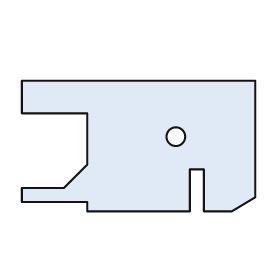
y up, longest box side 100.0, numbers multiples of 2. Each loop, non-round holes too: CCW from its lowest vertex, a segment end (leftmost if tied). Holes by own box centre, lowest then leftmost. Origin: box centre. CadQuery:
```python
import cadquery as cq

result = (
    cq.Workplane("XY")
    .moveTo(-22.0, -28.0)
    .lineTo(22.0, -28.0)
    .lineTo(22.0, -10.0)
    .lineTo(28.0, -10.0)
    .lineTo(28.0, -28.0)
    .lineTo(40.0, -28.0)
    .lineTo(50.0, -22.0)
    .lineTo(50.0, 28.0)
    .lineTo(-50.0, 28.0)
    .lineTo(-50.0, 14.0)
    .lineTo(-22.0, 14.0)
    .lineTo(-22.0, -8.0)
    .lineTo(-32.0, -18.0)
    .lineTo(-50.0, -18.0)
    .lineTo(-50.0, -24.0)
    .lineTo(-22.0, -24.0)
    .close()
    .moveTo(16.0, 4.0)
    .circle(4.0)
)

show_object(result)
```